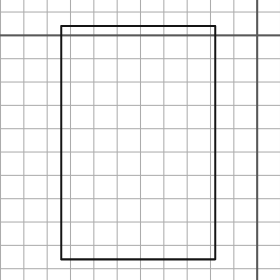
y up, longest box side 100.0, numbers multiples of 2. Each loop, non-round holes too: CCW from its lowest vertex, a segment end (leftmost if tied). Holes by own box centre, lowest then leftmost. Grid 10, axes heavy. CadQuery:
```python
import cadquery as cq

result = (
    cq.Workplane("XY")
    .moveTo(-84.0, -96.0)
    .lineTo(-18.0, -96.0)
    .lineTo(-18.0, 4.0)
    .lineTo(-84.0, 4.0)
    .close()
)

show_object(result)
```